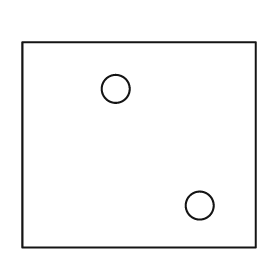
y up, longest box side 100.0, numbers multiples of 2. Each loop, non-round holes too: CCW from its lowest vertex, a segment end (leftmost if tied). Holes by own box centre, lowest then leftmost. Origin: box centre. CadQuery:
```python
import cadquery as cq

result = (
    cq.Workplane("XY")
    .moveTo(-50.0, -44.0)
    .lineTo(50.0, -44.0)
    .lineTo(50.0, 44.0)
    .lineTo(-50.0, 44.0)
    .close()
    .moveTo(26.0, -26.0)
    .circle(6.0)
    .moveTo(-10.0, 24.0)
    .circle(6.0)
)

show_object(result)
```